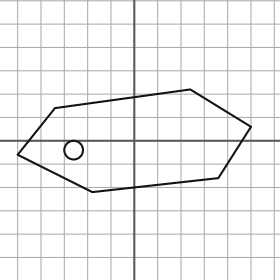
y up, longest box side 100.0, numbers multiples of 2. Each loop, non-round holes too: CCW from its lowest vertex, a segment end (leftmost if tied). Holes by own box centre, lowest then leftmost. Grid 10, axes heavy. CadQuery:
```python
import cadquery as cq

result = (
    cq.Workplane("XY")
    .moveTo(-18.0, -22.0)
    .lineTo(36.0, -16.0)
    .lineTo(50.0, 6.0)
    .lineTo(24.0, 22.0)
    .lineTo(-34.0, 14.0)
    .lineTo(-50.0, -6.0)
    .close()
    .moveTo(-26.0, -4.0)
    .circle(4.0)
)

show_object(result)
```